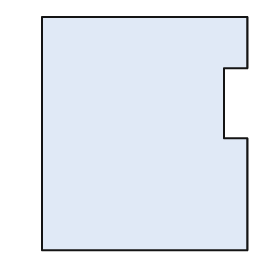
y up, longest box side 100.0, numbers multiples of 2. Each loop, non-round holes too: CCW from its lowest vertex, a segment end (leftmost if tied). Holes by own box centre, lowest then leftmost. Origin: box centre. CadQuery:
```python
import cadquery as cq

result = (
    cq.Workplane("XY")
    .moveTo(-44.0, -50.0)
    .lineTo(44.0, -50.0)
    .lineTo(44.0, -2.0)
    .lineTo(34.0, -2.0)
    .lineTo(34.0, 28.0)
    .lineTo(44.0, 28.0)
    .lineTo(44.0, 50.0)
    .lineTo(-44.0, 50.0)
    .close()
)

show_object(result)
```